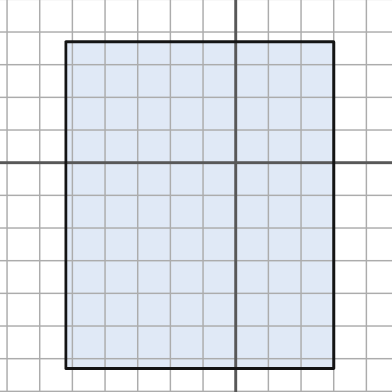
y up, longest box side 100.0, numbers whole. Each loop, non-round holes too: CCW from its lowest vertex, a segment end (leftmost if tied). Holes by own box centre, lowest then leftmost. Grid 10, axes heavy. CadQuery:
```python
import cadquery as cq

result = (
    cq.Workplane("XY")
    .moveTo(-52.0, -63.0)
    .lineTo(30.0, -63.0)
    .lineTo(30.0, 37.0)
    .lineTo(-52.0, 37.0)
    .close()
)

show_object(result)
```